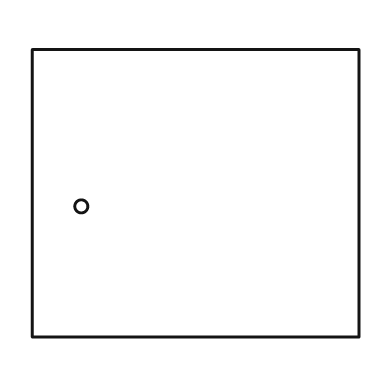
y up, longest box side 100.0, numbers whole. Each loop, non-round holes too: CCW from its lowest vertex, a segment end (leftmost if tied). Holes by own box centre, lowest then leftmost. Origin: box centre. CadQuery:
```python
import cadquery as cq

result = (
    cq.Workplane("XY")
    .moveTo(-50.0, -44.0)
    .lineTo(50.0, -44.0)
    .lineTo(50.0, 44.0)
    .lineTo(-50.0, 44.0)
    .close()
    .moveTo(-35.0, -4.0)
    .circle(2.0)
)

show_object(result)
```